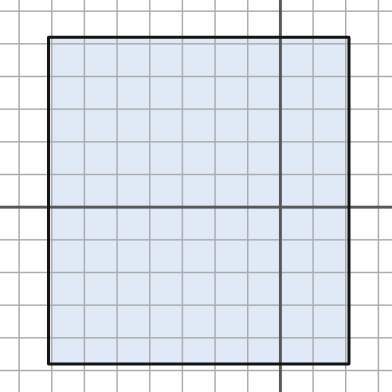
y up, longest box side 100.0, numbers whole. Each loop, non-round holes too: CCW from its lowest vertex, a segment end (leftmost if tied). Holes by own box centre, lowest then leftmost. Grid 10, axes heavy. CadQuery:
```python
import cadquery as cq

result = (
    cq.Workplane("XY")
    .moveTo(-71.0, -48.0)
    .lineTo(21.0, -48.0)
    .lineTo(21.0, 52.0)
    .lineTo(-71.0, 52.0)
    .close()
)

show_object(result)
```